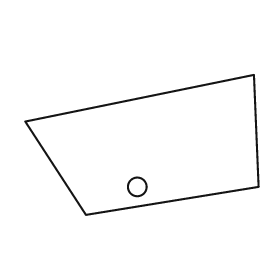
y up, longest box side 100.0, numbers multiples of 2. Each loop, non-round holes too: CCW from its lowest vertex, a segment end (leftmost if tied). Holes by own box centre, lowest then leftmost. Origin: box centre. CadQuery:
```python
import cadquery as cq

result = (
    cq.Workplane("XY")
    .moveTo(-24.0, -30.0)
    .lineTo(50.0, -18.0)
    .lineTo(48.0, 30.0)
    .lineTo(-50.0, 10.0)
    .close()
    .moveTo(-2.0, -18.0)
    .circle(4.0)
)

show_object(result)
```